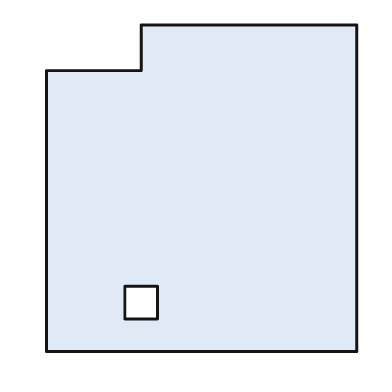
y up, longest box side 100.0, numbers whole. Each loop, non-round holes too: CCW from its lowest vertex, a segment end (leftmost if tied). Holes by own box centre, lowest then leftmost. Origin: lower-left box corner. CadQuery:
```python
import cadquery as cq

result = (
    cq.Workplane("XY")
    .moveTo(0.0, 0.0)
    .lineTo(95.0, 0.0)
    .lineTo(95.0, 100.0)
    .lineTo(29.0, 100.0)
    .lineTo(29.0, 86.0)
    .lineTo(0.0, 86.0)
    .close()
    .moveTo(24.0, 10.0)
    .lineTo(34.0, 10.0)
    .lineTo(34.0, 20.0)
    .lineTo(24.0, 20.0)
    .close()
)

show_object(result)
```